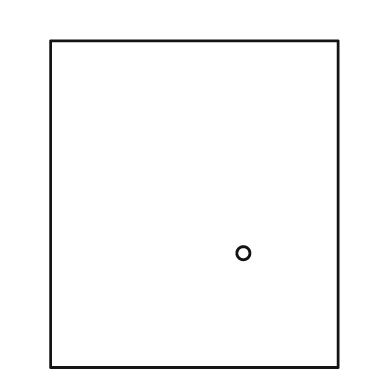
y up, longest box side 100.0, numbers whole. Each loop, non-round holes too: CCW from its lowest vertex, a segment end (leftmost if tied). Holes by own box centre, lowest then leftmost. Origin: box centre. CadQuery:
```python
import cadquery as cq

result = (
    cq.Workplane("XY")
    .moveTo(-44.0, -50.0)
    .lineTo(44.0, -50.0)
    .lineTo(44.0, 50.0)
    .lineTo(-44.0, 50.0)
    .close()
    .moveTo(15.0, -15.0)
    .circle(2.0)
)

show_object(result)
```